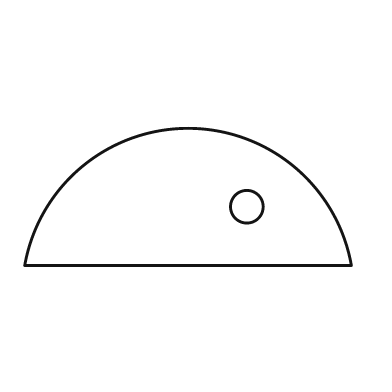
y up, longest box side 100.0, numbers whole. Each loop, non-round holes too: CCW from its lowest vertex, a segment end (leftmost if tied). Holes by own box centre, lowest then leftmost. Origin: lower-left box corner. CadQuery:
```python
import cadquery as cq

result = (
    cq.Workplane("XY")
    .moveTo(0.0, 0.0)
    .lineTo(100.0, 0.0)
    .threePointArc((50.0, 42.0), (0.0, 0.0))
    .close()
    .moveTo(68.0, 18.0)
    .circle(5.0)
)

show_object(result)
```